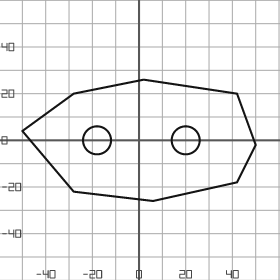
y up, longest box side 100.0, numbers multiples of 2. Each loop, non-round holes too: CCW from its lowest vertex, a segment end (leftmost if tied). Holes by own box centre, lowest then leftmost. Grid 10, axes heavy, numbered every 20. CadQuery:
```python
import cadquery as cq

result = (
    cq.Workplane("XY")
    .moveTo(6.0, -26.0)
    .lineTo(42.0, -18.0)
    .lineTo(50.0, -2.0)
    .lineTo(42.0, 20.0)
    .lineTo(2.0, 26.0)
    .lineTo(-28.0, 20.0)
    .lineTo(-50.0, 4.0)
    .lineTo(-28.0, -22.0)
    .close()
    .moveTo(-18.0, 0.0)
    .circle(6.0)
    .moveTo(20.0, 0.0)
    .circle(6.0)
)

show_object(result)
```